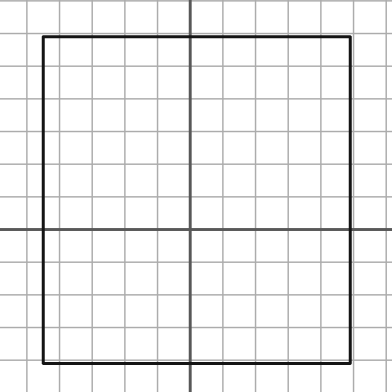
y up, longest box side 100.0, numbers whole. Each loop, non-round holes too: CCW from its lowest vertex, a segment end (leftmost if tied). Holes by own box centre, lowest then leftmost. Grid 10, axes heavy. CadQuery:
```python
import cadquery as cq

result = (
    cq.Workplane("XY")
    .moveTo(-45.0, -41.0)
    .lineTo(49.0, -41.0)
    .lineTo(49.0, 59.0)
    .lineTo(-45.0, 59.0)
    .close()
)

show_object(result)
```